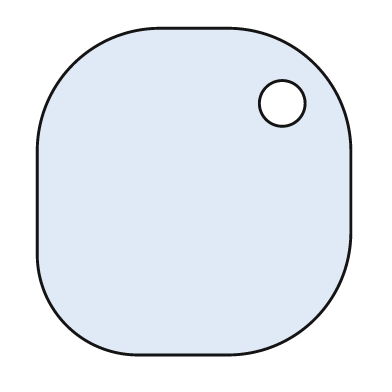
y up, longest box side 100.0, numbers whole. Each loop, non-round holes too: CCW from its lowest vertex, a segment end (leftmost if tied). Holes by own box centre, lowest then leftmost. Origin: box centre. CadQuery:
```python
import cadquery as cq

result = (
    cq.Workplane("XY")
    .moveTo(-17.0, -50.0)
    .lineTo(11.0, -50.0)
    .threePointArc((37.0, -39.0), (48.0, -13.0))
    .lineTo(48.0, 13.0)
    .threePointArc((37.0, 39.0), (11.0, 50.0))
    .lineTo(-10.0, 50.0)
    .threePointArc((-37.0, 39.0), (-48.0, 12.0))
    .lineTo(-48.0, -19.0)
    .threePointArc((-39.0, -41.0), (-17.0, -50.0))
    .close()
    .moveTo(27.0, 27.0)
    .circle(7.0)
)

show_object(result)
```